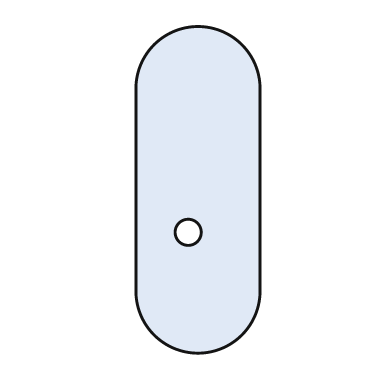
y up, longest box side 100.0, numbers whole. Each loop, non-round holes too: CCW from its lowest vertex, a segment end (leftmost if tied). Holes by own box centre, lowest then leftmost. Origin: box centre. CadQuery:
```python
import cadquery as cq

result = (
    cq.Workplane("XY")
    .moveTo(-19.0, -31.0)
    .threePointArc((0.0, -50.0), (19.0, -31.0))
    .lineTo(19.0, 31.0)
    .threePointArc((0.0, 50.0), (-19.0, 31.0))
    .close()
    .moveTo(-3.0, -13.0)
    .circle(4.0)
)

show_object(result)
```